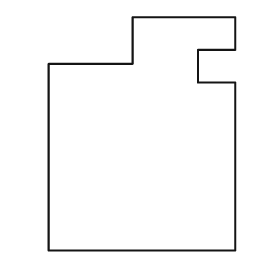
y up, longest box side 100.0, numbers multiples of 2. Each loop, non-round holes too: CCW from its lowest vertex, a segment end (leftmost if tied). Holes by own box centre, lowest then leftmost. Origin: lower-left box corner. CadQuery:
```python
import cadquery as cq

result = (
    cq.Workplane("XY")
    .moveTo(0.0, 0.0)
    .lineTo(80.0, 0.0)
    .lineTo(80.0, 72.0)
    .lineTo(64.0, 72.0)
    .lineTo(64.0, 86.0)
    .lineTo(80.0, 86.0)
    .lineTo(80.0, 100.0)
    .lineTo(36.0, 100.0)
    .lineTo(36.0, 80.0)
    .lineTo(0.0, 80.0)
    .close()
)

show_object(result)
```